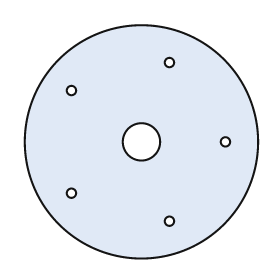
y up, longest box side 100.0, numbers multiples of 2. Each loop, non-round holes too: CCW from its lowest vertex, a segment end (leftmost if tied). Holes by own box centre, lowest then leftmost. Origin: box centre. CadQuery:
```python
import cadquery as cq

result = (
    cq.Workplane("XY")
    .moveTo(0.0, 0.0)
    .circle(50.0)
    .moveTo(12.0, -34.0)
    .circle(2.0)
    .moveTo(-30.0, -22.0)
    .circle(2.0)
    .moveTo(0.0, 0.0)
    .circle(8.0)
    .moveTo(36.0, 0.0)
    .circle(2.0)
    .moveTo(-30.0, 22.0)
    .circle(2.0)
    .moveTo(12.0, 34.0)
    .circle(2.0)
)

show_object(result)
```